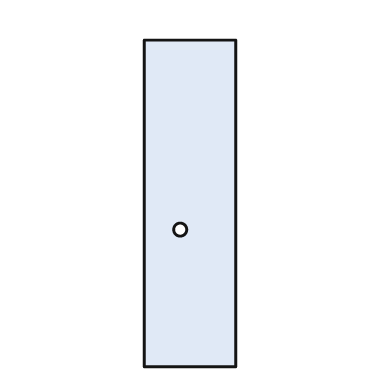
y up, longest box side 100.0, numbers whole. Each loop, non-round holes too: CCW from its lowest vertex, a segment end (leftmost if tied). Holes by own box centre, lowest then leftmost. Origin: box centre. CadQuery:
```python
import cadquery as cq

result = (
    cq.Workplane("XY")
    .moveTo(-14.0, -50.0)
    .lineTo(14.0, -50.0)
    .lineTo(14.0, 50.0)
    .lineTo(-14.0, 50.0)
    .close()
    .moveTo(-3.0, -8.0)
    .circle(2.0)
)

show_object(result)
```